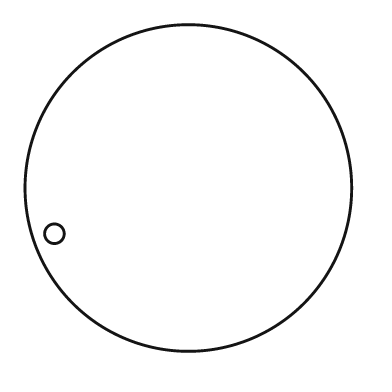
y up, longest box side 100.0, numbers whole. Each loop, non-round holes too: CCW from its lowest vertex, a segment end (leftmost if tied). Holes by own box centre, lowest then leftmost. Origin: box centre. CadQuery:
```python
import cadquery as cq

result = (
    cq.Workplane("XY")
    .moveTo(0.0, 0.0)
    .circle(50.0)
    .moveTo(-41.0, -14.0)
    .circle(3.0)
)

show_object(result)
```